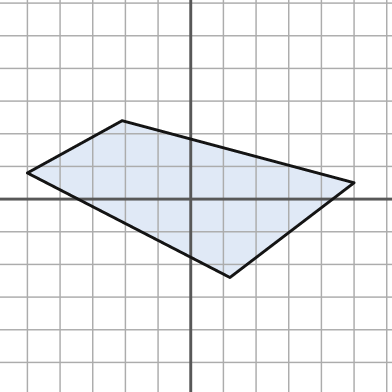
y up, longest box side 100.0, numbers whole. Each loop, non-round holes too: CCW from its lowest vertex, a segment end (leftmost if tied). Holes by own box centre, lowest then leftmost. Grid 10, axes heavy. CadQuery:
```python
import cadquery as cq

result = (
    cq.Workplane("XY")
    .moveTo(12.0, -24.0)
    .lineTo(50.0, 5.0)
    .lineTo(-21.0, 24.0)
    .lineTo(-50.0, 8.0)
    .close()
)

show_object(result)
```